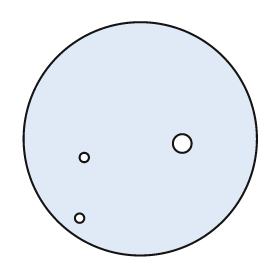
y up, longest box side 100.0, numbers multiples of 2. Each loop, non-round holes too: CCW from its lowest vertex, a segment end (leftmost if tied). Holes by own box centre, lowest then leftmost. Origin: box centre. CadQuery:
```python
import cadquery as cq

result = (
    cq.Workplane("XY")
    .moveTo(0.0, 0.0)
    .circle(50.0)
    .moveTo(-26.0, -34.0)
    .circle(2.0)
    .moveTo(-24.0, -8.0)
    .circle(2.0)
    .moveTo(18.0, -2.0)
    .circle(4.0)
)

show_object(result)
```